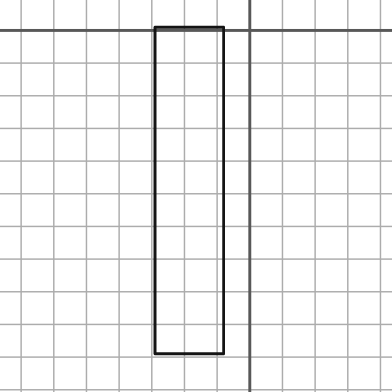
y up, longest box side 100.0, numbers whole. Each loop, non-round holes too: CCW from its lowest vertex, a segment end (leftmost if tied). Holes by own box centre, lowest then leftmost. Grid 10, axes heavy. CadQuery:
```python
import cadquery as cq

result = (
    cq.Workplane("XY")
    .moveTo(-29.0, -99.0)
    .lineTo(-8.0, -99.0)
    .lineTo(-8.0, 1.0)
    .lineTo(-29.0, 1.0)
    .close()
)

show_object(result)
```